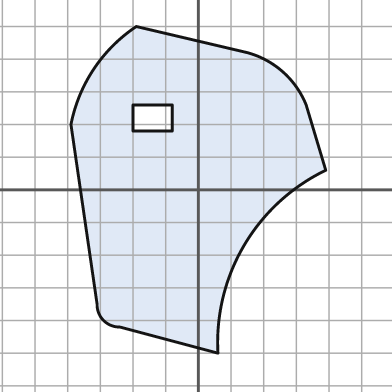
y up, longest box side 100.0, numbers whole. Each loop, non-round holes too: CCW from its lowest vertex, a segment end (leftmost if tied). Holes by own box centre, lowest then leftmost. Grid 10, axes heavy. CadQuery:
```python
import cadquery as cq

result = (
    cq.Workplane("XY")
    .moveTo(6.0, -50.0)
    .threePointArc((14.0, -17.0), (39.0, 6.0))
    .lineTo(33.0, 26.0)
    .threePointArc((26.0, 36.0), (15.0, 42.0))
    .lineTo(-19.0, 50.0)
    .threePointArc((-32.0, 37.0), (-39.0, 20.0))
    .lineTo(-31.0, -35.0)
    .threePointArc((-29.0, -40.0), (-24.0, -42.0))
    .close()
    .moveTo(-20.0, 18.0)
    .lineTo(-8.0, 18.0)
    .lineTo(-8.0, 26.0)
    .lineTo(-20.0, 26.0)
    .close()
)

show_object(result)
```